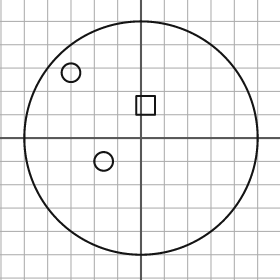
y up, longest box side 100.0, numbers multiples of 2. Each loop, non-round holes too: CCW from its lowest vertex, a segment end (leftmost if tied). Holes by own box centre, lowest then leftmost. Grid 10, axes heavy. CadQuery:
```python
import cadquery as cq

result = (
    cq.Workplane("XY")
    .moveTo(0.0, 0.0)
    .circle(50.0)
    .moveTo(-16.0, -10.0)
    .circle(4.0)
    .moveTo(-2.0, 10.0)
    .lineTo(6.0, 10.0)
    .lineTo(6.0, 18.0)
    .lineTo(-2.0, 18.0)
    .close()
    .moveTo(-30.0, 28.0)
    .circle(4.0)
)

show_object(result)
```